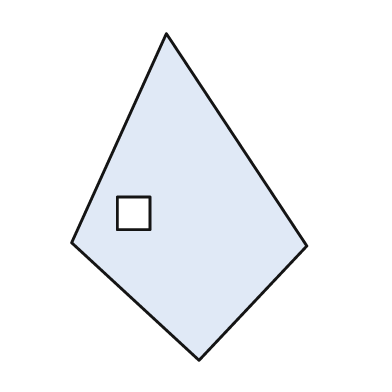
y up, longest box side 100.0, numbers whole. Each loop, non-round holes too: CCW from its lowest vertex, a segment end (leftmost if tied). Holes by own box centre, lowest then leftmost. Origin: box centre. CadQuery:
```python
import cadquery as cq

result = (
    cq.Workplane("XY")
    .moveTo(3.0, -50.0)
    .lineTo(36.0, -15.0)
    .lineTo(-7.0, 50.0)
    .lineTo(-36.0, -14.0)
    .close()
    .moveTo(-22.0, -10.0)
    .lineTo(-12.0, -10.0)
    .lineTo(-12.0, 0.0)
    .lineTo(-22.0, 0.0)
    .close()
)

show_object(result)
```